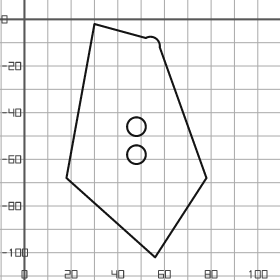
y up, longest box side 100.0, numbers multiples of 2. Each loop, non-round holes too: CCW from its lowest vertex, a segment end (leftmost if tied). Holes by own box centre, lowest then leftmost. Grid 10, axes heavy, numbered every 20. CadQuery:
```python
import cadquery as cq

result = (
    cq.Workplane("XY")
    .moveTo(56.0, -102.0)
    .lineTo(78.0, -68.0)
    .lineTo(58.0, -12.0)
    .threePointArc((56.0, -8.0), (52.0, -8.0))
    .lineTo(30.0, -2.0)
    .lineTo(18.0, -68.0)
    .close()
    .moveTo(48.0, -58.0)
    .circle(4.0)
    .moveTo(48.0, -46.0)
    .circle(4.0)
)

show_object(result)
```